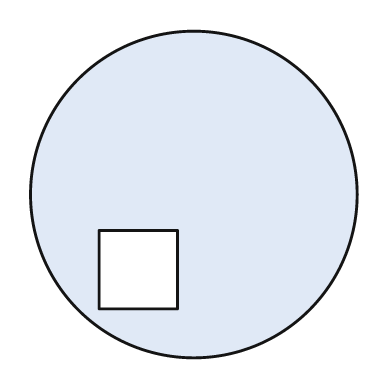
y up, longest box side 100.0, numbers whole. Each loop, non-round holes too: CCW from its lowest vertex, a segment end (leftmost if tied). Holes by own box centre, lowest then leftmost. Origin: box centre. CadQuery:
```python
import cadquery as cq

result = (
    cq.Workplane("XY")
    .moveTo(0.0, 0.0)
    .circle(50.0)
    .moveTo(-29.0, -35.0)
    .lineTo(-5.0, -35.0)
    .lineTo(-5.0, -11.0)
    .lineTo(-29.0, -11.0)
    .close()
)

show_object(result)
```